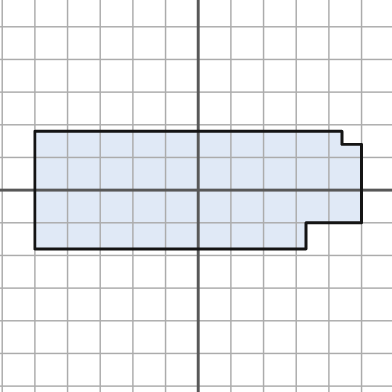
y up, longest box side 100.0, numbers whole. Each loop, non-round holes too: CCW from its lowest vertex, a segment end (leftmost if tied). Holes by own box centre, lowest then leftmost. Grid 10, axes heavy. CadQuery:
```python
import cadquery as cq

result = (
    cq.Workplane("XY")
    .moveTo(-50.0, -18.0)
    .lineTo(33.0, -18.0)
    .lineTo(33.0, -10.0)
    .lineTo(50.0, -10.0)
    .lineTo(50.0, 14.0)
    .lineTo(44.0, 14.0)
    .lineTo(44.0, 18.0)
    .lineTo(-50.0, 18.0)
    .close()
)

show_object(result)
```